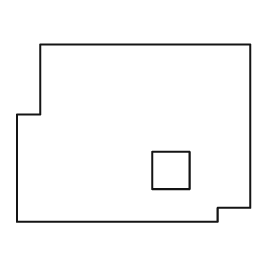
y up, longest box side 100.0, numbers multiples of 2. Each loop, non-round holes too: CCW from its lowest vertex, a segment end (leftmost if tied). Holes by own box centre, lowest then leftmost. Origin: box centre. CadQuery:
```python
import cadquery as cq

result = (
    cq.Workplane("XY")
    .moveTo(-50.0, -38.0)
    .lineTo(36.0, -38.0)
    .lineTo(36.0, -32.0)
    .lineTo(50.0, -32.0)
    .lineTo(50.0, 38.0)
    .lineTo(-40.0, 38.0)
    .lineTo(-40.0, 8.0)
    .lineTo(-50.0, 8.0)
    .close()
    .moveTo(8.0, -24.0)
    .lineTo(24.0, -24.0)
    .lineTo(24.0, -8.0)
    .lineTo(8.0, -8.0)
    .close()
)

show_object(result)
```